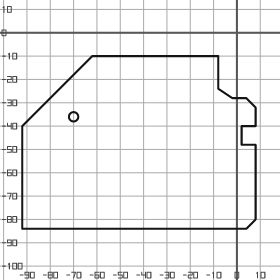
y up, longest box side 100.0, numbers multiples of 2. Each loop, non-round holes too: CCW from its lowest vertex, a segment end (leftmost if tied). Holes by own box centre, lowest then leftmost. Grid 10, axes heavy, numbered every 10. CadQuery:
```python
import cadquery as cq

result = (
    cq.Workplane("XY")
    .moveTo(-92.0, -84.0)
    .lineTo(4.0, -84.0)
    .lineTo(8.0, -80.0)
    .lineTo(8.0, -48.0)
    .lineTo(2.0, -48.0)
    .lineTo(2.0, -40.0)
    .lineTo(8.0, -40.0)
    .lineTo(8.0, -32.0)
    .lineTo(4.0, -28.0)
    .lineTo(-2.0, -28.0)
    .lineTo(-8.0, -24.0)
    .lineTo(-8.0, -10.0)
    .lineTo(-62.0, -10.0)
    .lineTo(-92.0, -40.0)
    .close()
    .moveTo(-70.0, -36.0)
    .circle(2.0)
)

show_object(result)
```